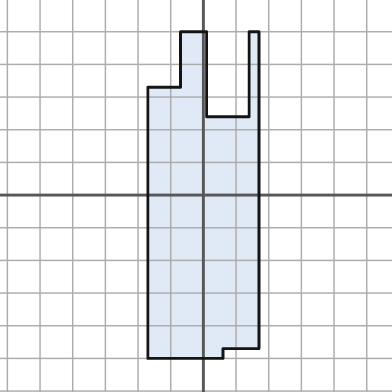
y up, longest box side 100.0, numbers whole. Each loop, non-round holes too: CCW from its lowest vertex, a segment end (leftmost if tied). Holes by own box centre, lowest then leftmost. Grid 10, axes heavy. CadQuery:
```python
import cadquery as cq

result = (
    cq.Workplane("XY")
    .moveTo(-17.0, -50.0)
    .lineTo(6.0, -50.0)
    .lineTo(6.0, -47.0)
    .lineTo(17.0, -47.0)
    .lineTo(17.0, 50.0)
    .lineTo(14.0, 50.0)
    .lineTo(14.0, 24.0)
    .lineTo(1.0, 24.0)
    .lineTo(1.0, 50.0)
    .lineTo(-7.0, 50.0)
    .lineTo(-7.0, 33.0)
    .lineTo(-17.0, 33.0)
    .close()
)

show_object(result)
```